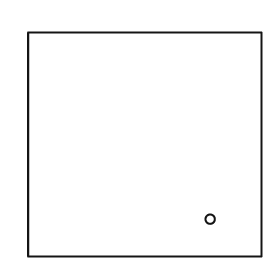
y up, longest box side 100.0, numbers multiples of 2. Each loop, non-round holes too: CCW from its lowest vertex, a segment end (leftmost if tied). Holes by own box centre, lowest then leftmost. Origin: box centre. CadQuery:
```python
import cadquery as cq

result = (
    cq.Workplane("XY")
    .moveTo(-50.0, -48.0)
    .lineTo(50.0, -48.0)
    .lineTo(50.0, 48.0)
    .lineTo(-50.0, 48.0)
    .close()
    .moveTo(28.0, -32.0)
    .circle(2.0)
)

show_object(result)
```